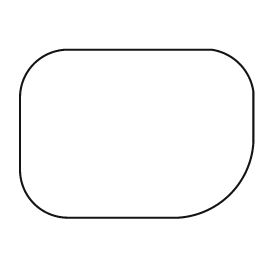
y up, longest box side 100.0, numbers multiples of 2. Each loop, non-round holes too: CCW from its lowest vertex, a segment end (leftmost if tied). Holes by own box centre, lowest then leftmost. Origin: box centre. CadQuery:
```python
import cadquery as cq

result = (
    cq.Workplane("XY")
    .moveTo(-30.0, -36.0)
    .lineTo(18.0, -36.0)
    .threePointArc((40.0, -26.0), (50.0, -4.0))
    .lineTo(50.0, 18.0)
    .threePointArc((44.0, 30.0), (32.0, 36.0))
    .lineTo(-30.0, 36.0)
    .threePointArc((-44.0, 30.0), (-50.0, 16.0))
    .lineTo(-50.0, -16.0)
    .threePointArc((-44.0, -30.0), (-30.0, -36.0))
    .close()
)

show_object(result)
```